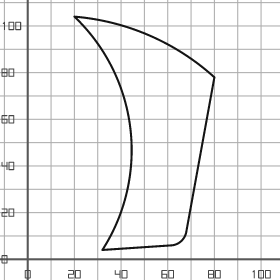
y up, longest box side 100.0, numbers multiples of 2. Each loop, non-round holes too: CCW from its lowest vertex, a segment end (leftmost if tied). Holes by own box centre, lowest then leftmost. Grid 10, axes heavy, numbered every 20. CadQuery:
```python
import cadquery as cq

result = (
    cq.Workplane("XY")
    .moveTo(32.0, 4.0)
    .lineTo(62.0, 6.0)
    .threePointArc((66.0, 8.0), (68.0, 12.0))
    .lineTo(80.0, 78.0)
    .threePointArc((52.0, 96.0), (20.0, 104.0))
    .threePointArc((44.0, 56.0), (32.0, 4.0))
    .close()
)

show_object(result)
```